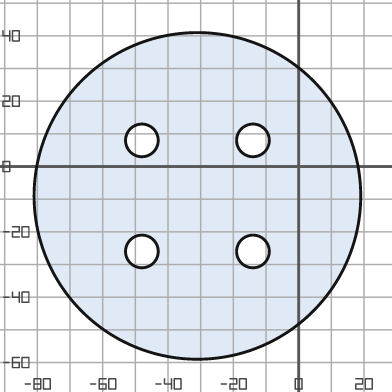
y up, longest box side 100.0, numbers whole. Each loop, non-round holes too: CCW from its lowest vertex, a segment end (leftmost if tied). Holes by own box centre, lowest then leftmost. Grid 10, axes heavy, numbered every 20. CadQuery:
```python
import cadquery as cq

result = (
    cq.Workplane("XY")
    .moveTo(-31.0, -9.0)
    .circle(50.0)
    .moveTo(-48.0, -26.0)
    .circle(5.0)
    .moveTo(-14.0, -26.0)
    .circle(5.0)
    .moveTo(-48.0, 8.0)
    .circle(5.0)
    .moveTo(-14.0, 8.0)
    .circle(5.0)
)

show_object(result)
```